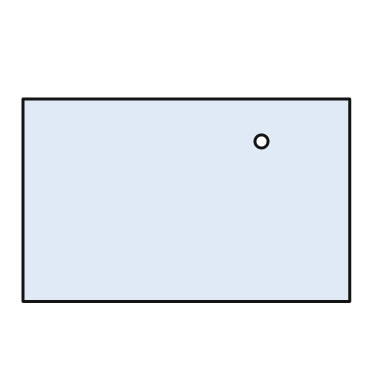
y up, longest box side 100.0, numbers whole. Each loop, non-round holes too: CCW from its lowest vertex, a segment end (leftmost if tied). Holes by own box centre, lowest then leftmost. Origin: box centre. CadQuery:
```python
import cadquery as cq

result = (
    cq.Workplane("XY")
    .moveTo(-50.0, -31.0)
    .lineTo(50.0, -31.0)
    .lineTo(50.0, 31.0)
    .lineTo(-50.0, 31.0)
    .close()
    .moveTo(23.0, 18.0)
    .circle(2.0)
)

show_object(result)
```